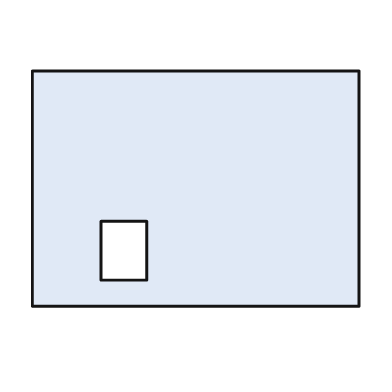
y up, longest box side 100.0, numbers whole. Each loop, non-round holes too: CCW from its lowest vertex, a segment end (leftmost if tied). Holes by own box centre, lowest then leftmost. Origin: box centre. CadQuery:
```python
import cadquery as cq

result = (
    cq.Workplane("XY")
    .moveTo(-50.0, -36.0)
    .lineTo(50.0, -36.0)
    .lineTo(50.0, 36.0)
    .lineTo(-50.0, 36.0)
    .close()
    .moveTo(-29.0, -28.0)
    .lineTo(-15.0, -28.0)
    .lineTo(-15.0, -10.0)
    .lineTo(-29.0, -10.0)
    .close()
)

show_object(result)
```